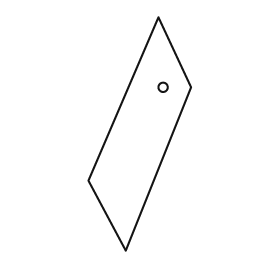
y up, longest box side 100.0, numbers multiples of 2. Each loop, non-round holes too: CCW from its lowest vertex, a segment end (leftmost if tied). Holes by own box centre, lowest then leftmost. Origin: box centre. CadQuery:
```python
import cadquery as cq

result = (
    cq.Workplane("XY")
    .moveTo(-6.0, -50.0)
    .lineTo(22.0, 20.0)
    .lineTo(8.0, 50.0)
    .lineTo(-22.0, -20.0)
    .close()
    .moveTo(10.0, 20.0)
    .circle(2.0)
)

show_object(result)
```